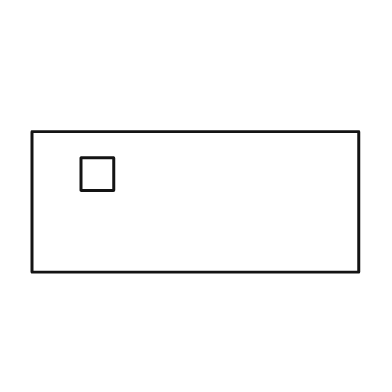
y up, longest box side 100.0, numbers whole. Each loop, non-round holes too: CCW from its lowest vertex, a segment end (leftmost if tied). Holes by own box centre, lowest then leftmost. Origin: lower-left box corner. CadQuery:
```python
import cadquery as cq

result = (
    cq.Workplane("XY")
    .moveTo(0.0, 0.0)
    .lineTo(100.0, 0.0)
    .lineTo(100.0, 43.0)
    .lineTo(0.0, 43.0)
    .close()
    .moveTo(15.0, 25.0)
    .lineTo(25.0, 25.0)
    .lineTo(25.0, 35.0)
    .lineTo(15.0, 35.0)
    .close()
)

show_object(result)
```